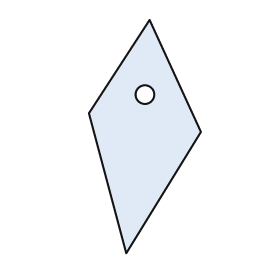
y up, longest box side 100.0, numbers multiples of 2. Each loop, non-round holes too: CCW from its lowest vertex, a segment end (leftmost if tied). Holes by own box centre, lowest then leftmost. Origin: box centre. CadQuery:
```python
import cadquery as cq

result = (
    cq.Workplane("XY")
    .moveTo(-8.0, -50.0)
    .lineTo(24.0, 2.0)
    .lineTo(2.0, 50.0)
    .lineTo(-24.0, 10.0)
    .close()
    .moveTo(0.0, 18.0)
    .circle(4.0)
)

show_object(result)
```